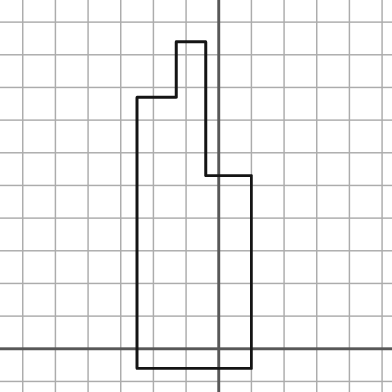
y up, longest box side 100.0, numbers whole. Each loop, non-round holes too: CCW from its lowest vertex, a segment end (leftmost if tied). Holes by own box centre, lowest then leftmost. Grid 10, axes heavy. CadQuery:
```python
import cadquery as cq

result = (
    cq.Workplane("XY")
    .moveTo(-25.0, -6.0)
    .lineTo(10.0, -6.0)
    .lineTo(10.0, 53.0)
    .lineTo(-4.0, 53.0)
    .lineTo(-4.0, 94.0)
    .lineTo(-13.0, 94.0)
    .lineTo(-13.0, 77.0)
    .lineTo(-25.0, 77.0)
    .close()
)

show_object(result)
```